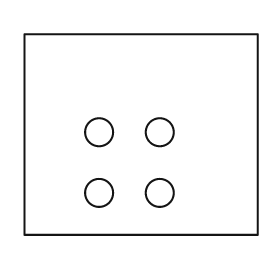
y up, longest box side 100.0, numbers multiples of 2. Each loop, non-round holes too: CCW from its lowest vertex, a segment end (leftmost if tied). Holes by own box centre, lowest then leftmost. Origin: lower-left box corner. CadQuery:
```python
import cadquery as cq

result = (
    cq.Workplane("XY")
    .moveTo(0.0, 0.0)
    .lineTo(100.0, 0.0)
    .lineTo(100.0, 86.0)
    .lineTo(0.0, 86.0)
    .close()
    .moveTo(32.0, 18.0)
    .circle(6.0)
    .moveTo(58.0, 18.0)
    .circle(6.0)
    .moveTo(32.0, 44.0)
    .circle(6.0)
    .moveTo(58.0, 44.0)
    .circle(6.0)
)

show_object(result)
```